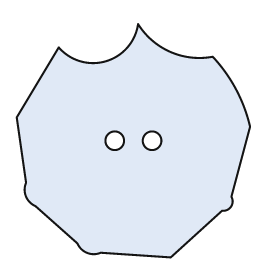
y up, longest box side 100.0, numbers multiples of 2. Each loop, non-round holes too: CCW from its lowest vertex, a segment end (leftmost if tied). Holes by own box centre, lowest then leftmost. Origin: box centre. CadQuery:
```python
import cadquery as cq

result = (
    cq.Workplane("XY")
    .moveTo(16.0, -50.0)
    .lineTo(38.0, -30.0)
    .threePointArc((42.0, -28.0), (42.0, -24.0))
    .lineTo(50.0, 6.0)
    .threePointArc((44.0, 22.0), (34.0, 36.0))
    .threePointArc((16.0, 38.0), (2.0, 50.0))
    .threePointArc((-12.0, 34.0), (-32.0, 40.0))
    .lineTo(-50.0, 10.0)
    .lineTo(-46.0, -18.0)
    .threePointArc((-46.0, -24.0), (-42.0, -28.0))
    .lineTo(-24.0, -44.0)
    .threePointArc((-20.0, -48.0), (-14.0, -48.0))
    .close()
    .moveTo(-8.0, 0.0)
    .circle(4.0)
    .moveTo(8.0, 0.0)
    .circle(4.0)
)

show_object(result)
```